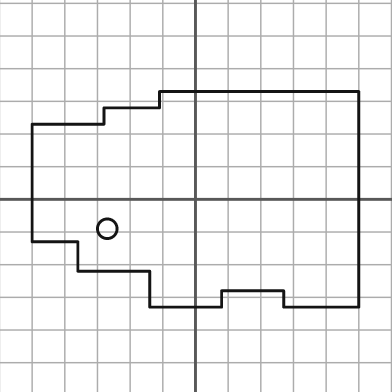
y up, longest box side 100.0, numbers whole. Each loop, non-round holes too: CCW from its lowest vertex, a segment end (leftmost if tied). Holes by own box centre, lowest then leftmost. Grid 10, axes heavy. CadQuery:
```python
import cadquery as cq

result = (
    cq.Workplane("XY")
    .moveTo(-14.0, -33.0)
    .lineTo(8.0, -33.0)
    .lineTo(8.0, -28.0)
    .lineTo(27.0, -28.0)
    .lineTo(27.0, -33.0)
    .lineTo(50.0, -33.0)
    .lineTo(50.0, 33.0)
    .lineTo(-11.0, 33.0)
    .lineTo(-11.0, 28.0)
    .lineTo(-28.0, 28.0)
    .lineTo(-28.0, 23.0)
    .lineTo(-50.0, 23.0)
    .lineTo(-50.0, -13.0)
    .lineTo(-36.0, -13.0)
    .lineTo(-36.0, -22.0)
    .lineTo(-14.0, -22.0)
    .close()
    .moveTo(-27.0, -9.0)
    .circle(3.0)
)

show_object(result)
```